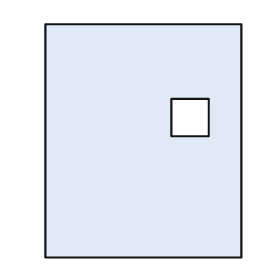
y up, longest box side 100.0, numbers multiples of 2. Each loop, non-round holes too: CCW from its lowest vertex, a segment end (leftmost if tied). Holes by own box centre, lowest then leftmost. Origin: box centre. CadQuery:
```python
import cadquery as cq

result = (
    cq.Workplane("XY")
    .moveTo(-42.0, -50.0)
    .lineTo(42.0, -50.0)
    .lineTo(42.0, 50.0)
    .lineTo(-42.0, 50.0)
    .close()
    .moveTo(12.0, 2.0)
    .lineTo(28.0, 2.0)
    .lineTo(28.0, 18.0)
    .lineTo(12.0, 18.0)
    .close()
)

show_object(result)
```